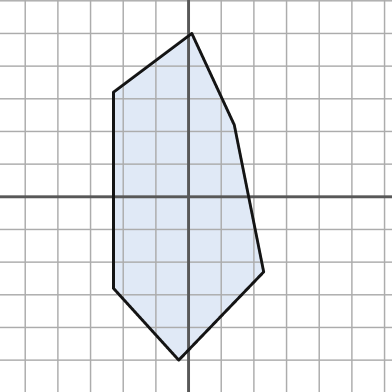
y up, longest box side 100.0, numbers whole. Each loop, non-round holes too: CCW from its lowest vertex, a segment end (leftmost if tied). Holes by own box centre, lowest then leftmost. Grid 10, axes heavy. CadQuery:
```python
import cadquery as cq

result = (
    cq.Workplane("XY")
    .moveTo(-3.0, -50.0)
    .lineTo(23.0, -23.0)
    .lineTo(14.0, 22.0)
    .lineTo(1.0, 50.0)
    .lineTo(-23.0, 32.0)
    .lineTo(-23.0, -28.0)
    .close()
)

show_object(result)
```